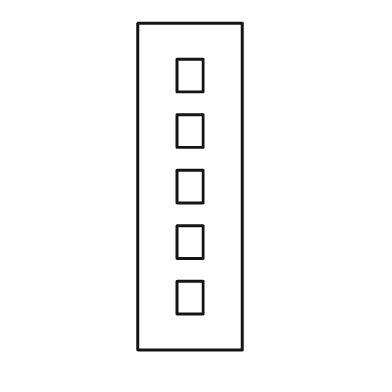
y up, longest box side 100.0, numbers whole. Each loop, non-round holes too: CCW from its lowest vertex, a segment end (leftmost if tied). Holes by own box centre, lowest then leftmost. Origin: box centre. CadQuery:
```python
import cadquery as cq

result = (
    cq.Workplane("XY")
    .moveTo(-16.0, -50.0)
    .lineTo(16.0, -50.0)
    .lineTo(16.0, 50.0)
    .lineTo(-16.0, 50.0)
    .close()
    .moveTo(-4.0, -39.0)
    .lineTo(4.0, -39.0)
    .lineTo(4.0, -29.0)
    .lineTo(-4.0, -29.0)
    .close()
    .moveTo(-4.0, -22.0)
    .lineTo(4.0, -22.0)
    .lineTo(4.0, -12.0)
    .lineTo(-4.0, -12.0)
    .close()
    .moveTo(-4.0, -5.0)
    .lineTo(4.0, -5.0)
    .lineTo(4.0, 5.0)
    .lineTo(-4.0, 5.0)
    .close()
    .moveTo(-4.0, 12.0)
    .lineTo(4.0, 12.0)
    .lineTo(4.0, 22.0)
    .lineTo(-4.0, 22.0)
    .close()
    .moveTo(-4.0, 29.0)
    .lineTo(4.0, 29.0)
    .lineTo(4.0, 39.0)
    .lineTo(-4.0, 39.0)
    .close()
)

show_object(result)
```